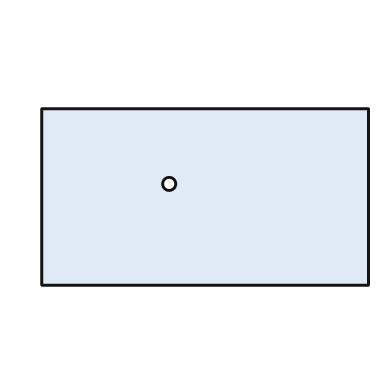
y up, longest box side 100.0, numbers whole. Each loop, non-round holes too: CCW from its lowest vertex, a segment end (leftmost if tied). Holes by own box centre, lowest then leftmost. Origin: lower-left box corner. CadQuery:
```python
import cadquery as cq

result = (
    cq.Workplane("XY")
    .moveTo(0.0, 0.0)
    .lineTo(100.0, 0.0)
    .lineTo(100.0, 54.0)
    .lineTo(0.0, 54.0)
    .close()
    .moveTo(39.0, 31.0)
    .circle(2.0)
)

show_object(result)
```